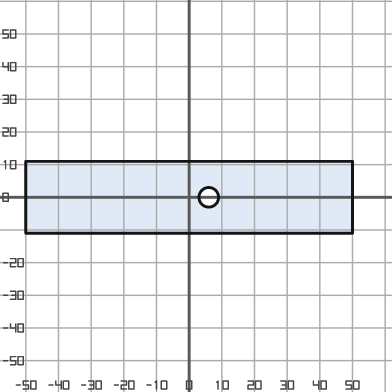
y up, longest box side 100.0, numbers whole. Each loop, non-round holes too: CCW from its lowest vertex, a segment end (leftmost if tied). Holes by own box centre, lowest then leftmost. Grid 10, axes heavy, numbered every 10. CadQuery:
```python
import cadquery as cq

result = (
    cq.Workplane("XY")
    .moveTo(-50.0, -11.0)
    .lineTo(50.0, -11.0)
    .lineTo(50.0, 11.0)
    .lineTo(-50.0, 11.0)
    .close()
    .moveTo(6.0, 0.0)
    .circle(3.0)
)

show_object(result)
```